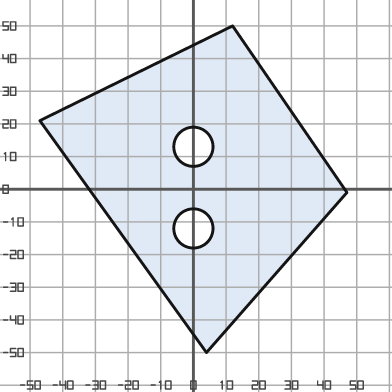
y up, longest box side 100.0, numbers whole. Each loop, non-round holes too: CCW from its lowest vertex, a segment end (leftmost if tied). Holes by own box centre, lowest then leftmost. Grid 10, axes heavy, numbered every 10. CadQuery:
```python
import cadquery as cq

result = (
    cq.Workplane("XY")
    .moveTo(4.0, -50.0)
    .lineTo(47.0, -1.0)
    .lineTo(12.0, 50.0)
    .lineTo(-47.0, 21.0)
    .close()
    .moveTo(0.0, -12.0)
    .circle(6.0)
    .moveTo(0.0, 13.0)
    .circle(6.0)
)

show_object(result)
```